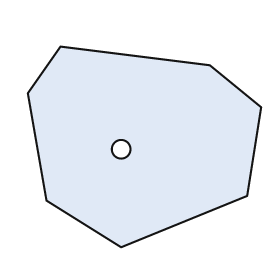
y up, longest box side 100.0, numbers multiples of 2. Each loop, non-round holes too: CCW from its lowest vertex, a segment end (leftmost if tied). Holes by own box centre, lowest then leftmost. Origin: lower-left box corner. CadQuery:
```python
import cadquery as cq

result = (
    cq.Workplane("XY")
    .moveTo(40.0, 0.0)
    .lineTo(94.0, 22.0)
    .lineTo(100.0, 60.0)
    .lineTo(78.0, 78.0)
    .lineTo(14.0, 86.0)
    .lineTo(0.0, 66.0)
    .lineTo(8.0, 20.0)
    .close()
    .moveTo(40.0, 42.0)
    .circle(4.0)
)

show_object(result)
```